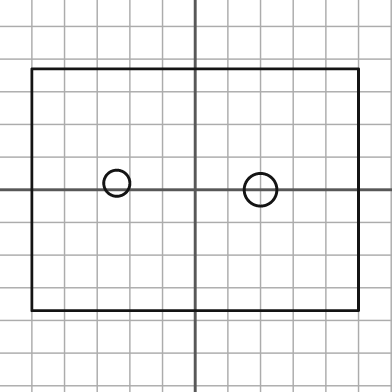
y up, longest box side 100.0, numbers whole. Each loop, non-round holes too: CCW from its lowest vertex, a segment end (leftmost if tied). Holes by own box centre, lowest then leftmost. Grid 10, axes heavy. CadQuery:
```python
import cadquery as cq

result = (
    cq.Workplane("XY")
    .moveTo(-50.0, -37.0)
    .lineTo(50.0, -37.0)
    .lineTo(50.0, 37.0)
    .lineTo(-50.0, 37.0)
    .close()
    .moveTo(20.0, 0.0)
    .circle(5.0)
    .moveTo(-24.0, 2.0)
    .circle(4.0)
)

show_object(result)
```